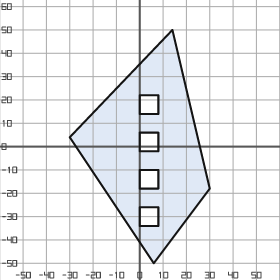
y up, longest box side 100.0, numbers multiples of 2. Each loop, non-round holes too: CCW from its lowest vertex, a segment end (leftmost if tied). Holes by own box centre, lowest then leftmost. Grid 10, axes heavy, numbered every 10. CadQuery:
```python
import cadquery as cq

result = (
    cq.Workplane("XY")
    .moveTo(6.0, -50.0)
    .lineTo(30.0, -18.0)
    .lineTo(14.0, 50.0)
    .lineTo(-30.0, 4.0)
    .close()
    .moveTo(0.0, -34.0)
    .lineTo(8.0, -34.0)
    .lineTo(8.0, -26.0)
    .lineTo(0.0, -26.0)
    .close()
    .moveTo(0.0, -18.0)
    .lineTo(8.0, -18.0)
    .lineTo(8.0, -10.0)
    .lineTo(0.0, -10.0)
    .close()
    .moveTo(0.0, -2.0)
    .lineTo(8.0, -2.0)
    .lineTo(8.0, 6.0)
    .lineTo(0.0, 6.0)
    .close()
    .moveTo(0.0, 14.0)
    .lineTo(8.0, 14.0)
    .lineTo(8.0, 22.0)
    .lineTo(0.0, 22.0)
    .close()
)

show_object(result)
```